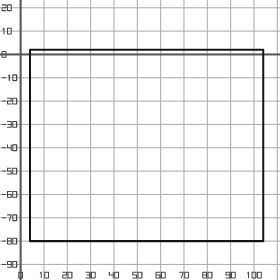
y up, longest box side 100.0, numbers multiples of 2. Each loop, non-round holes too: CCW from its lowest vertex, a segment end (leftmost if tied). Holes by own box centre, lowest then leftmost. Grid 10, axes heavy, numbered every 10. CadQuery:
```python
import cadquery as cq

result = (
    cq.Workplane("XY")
    .moveTo(4.0, -80.0)
    .lineTo(104.0, -80.0)
    .lineTo(104.0, 2.0)
    .lineTo(4.0, 2.0)
    .close()
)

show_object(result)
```